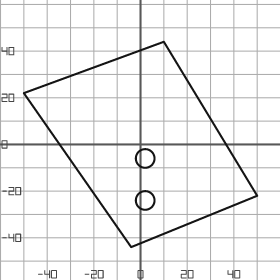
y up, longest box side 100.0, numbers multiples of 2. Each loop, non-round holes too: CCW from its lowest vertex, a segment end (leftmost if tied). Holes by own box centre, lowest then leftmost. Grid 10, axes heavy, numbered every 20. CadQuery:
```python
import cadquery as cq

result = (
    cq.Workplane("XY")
    .moveTo(-4.0, -44.0)
    .lineTo(50.0, -22.0)
    .lineTo(10.0, 44.0)
    .lineTo(-50.0, 22.0)
    .close()
    .moveTo(2.0, -24.0)
    .circle(4.0)
    .moveTo(2.0, -6.0)
    .circle(4.0)
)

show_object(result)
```